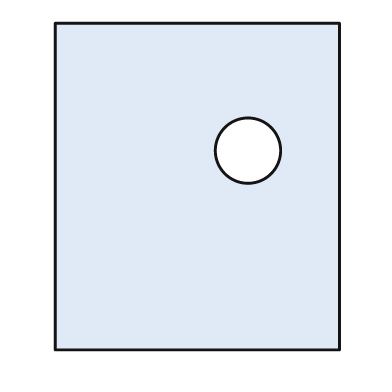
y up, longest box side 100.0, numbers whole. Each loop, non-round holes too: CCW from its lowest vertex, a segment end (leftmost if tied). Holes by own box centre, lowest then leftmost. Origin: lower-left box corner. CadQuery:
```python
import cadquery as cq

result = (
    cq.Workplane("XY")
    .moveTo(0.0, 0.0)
    .lineTo(87.0, 0.0)
    .lineTo(87.0, 100.0)
    .lineTo(0.0, 100.0)
    .close()
    .moveTo(59.0, 61.0)
    .circle(10.0)
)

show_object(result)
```